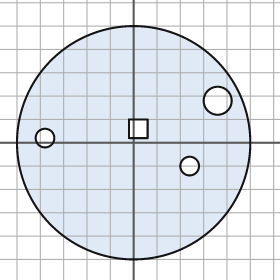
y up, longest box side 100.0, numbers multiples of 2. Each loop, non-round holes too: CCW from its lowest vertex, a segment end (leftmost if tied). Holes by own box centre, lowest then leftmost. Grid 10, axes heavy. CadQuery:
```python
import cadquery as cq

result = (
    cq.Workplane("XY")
    .moveTo(0.0, 0.0)
    .circle(50.0)
    .moveTo(24.0, -10.0)
    .circle(4.0)
    .moveTo(-38.0, 2.0)
    .circle(4.0)
    .moveTo(-2.0, 2.0)
    .lineTo(6.0, 2.0)
    .lineTo(6.0, 10.0)
    .lineTo(-2.0, 10.0)
    .close()
    .moveTo(36.0, 18.0)
    .circle(6.0)
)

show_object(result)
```